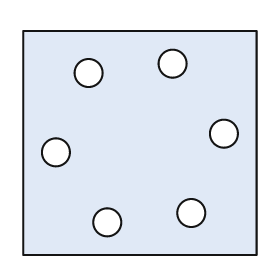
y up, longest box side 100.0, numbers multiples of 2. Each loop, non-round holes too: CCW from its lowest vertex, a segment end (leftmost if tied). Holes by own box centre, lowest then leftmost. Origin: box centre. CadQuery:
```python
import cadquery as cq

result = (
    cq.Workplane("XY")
    .moveTo(-50.0, -48.0)
    .lineTo(50.0, -48.0)
    .lineTo(50.0, 48.0)
    .lineTo(-50.0, 48.0)
    .close()
    .moveTo(-14.0, -34.0)
    .circle(6.0)
    .moveTo(22.0, -30.0)
    .circle(6.0)
    .moveTo(-36.0, -4.0)
    .circle(6.0)
    .moveTo(36.0, 4.0)
    .circle(6.0)
    .moveTo(-22.0, 30.0)
    .circle(6.0)
    .moveTo(14.0, 34.0)
    .circle(6.0)
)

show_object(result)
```